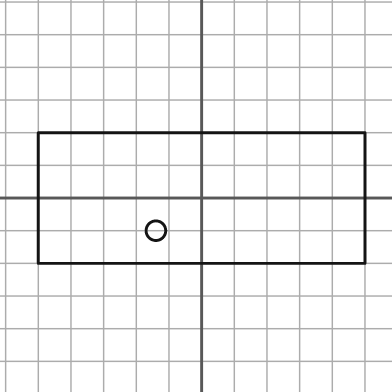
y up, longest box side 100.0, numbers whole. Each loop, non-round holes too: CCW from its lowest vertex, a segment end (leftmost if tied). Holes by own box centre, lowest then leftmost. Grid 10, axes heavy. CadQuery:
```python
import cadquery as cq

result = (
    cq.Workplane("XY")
    .moveTo(-50.0, -20.0)
    .lineTo(50.0, -20.0)
    .lineTo(50.0, 20.0)
    .lineTo(-50.0, 20.0)
    .close()
    .moveTo(-14.0, -10.0)
    .circle(3.0)
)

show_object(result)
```